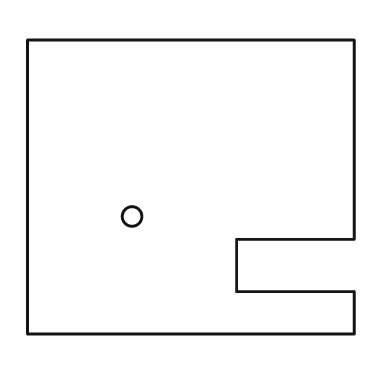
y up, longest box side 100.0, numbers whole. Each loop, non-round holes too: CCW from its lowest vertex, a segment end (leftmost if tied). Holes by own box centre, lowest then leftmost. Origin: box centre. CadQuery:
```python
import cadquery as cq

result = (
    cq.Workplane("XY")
    .moveTo(-50.0, -45.0)
    .lineTo(50.0, -45.0)
    .lineTo(50.0, -32.0)
    .lineTo(14.0, -32.0)
    .lineTo(14.0, -16.0)
    .lineTo(50.0, -16.0)
    .lineTo(50.0, 45.0)
    .lineTo(-50.0, 45.0)
    .close()
    .moveTo(-18.0, -9.0)
    .circle(3.0)
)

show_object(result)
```